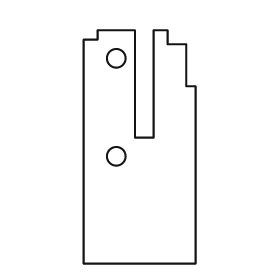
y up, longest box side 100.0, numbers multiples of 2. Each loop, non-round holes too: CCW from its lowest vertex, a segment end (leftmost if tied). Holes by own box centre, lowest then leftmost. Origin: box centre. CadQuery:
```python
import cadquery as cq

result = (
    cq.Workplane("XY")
    .moveTo(-24.0, -50.0)
    .lineTo(24.0, -50.0)
    .lineTo(24.0, 26.0)
    .lineTo(20.0, 26.0)
    .lineTo(20.0, 44.0)
    .lineTo(12.0, 44.0)
    .lineTo(12.0, 50.0)
    .lineTo(6.0, 50.0)
    .lineTo(6.0, 4.0)
    .lineTo(-2.0, 4.0)
    .lineTo(-2.0, 50.0)
    .lineTo(-18.0, 50.0)
    .lineTo(-18.0, 46.0)
    .lineTo(-24.0, 46.0)
    .close()
    .moveTo(-10.0, -4.0)
    .circle(4.0)
    .moveTo(-10.0, 38.0)
    .circle(4.0)
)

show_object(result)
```